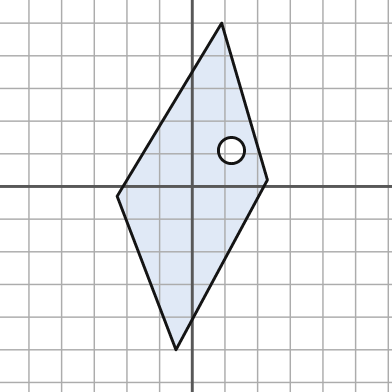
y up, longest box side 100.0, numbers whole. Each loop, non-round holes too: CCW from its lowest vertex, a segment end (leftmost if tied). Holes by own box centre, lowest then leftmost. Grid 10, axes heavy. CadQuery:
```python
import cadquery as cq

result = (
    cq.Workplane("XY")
    .moveTo(-5.0, -50.0)
    .lineTo(23.0, 2.0)
    .lineTo(9.0, 50.0)
    .lineTo(-23.0, -3.0)
    .close()
    .moveTo(12.0, 11.0)
    .circle(4.0)
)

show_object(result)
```